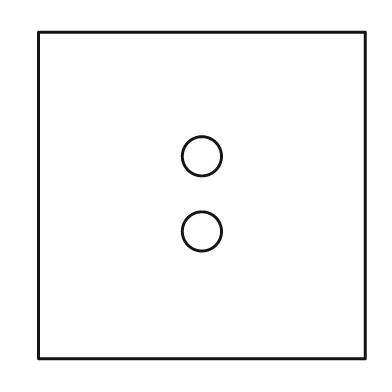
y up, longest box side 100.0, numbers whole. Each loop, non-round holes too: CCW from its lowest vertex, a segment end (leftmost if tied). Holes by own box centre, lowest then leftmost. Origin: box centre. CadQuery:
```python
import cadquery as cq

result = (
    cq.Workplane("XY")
    .moveTo(-50.0, -50.0)
    .lineTo(50.0, -50.0)
    .lineTo(50.0, 50.0)
    .lineTo(-50.0, 50.0)
    .close()
    .moveTo(0.0, -11.0)
    .circle(6.0)
    .moveTo(0.0, 12.0)
    .circle(6.0)
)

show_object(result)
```